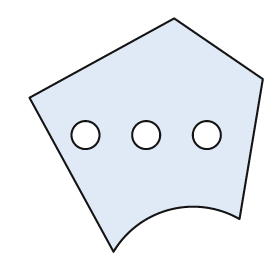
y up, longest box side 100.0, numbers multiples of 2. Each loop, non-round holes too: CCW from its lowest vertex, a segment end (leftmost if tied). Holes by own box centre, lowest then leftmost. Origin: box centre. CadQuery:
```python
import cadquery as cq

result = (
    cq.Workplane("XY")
    .moveTo(-14.0, -50.0)
    .threePointArc((10.0, -32.0), (40.0, -36.0))
    .lineTo(50.0, 24.0)
    .lineTo(12.0, 50.0)
    .lineTo(-50.0, 16.0)
    .close()
    .moveTo(-26.0, 0.0)
    .circle(6.0)
    .moveTo(0.0, 0.0)
    .circle(6.0)
    .moveTo(26.0, 0.0)
    .circle(6.0)
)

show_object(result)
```